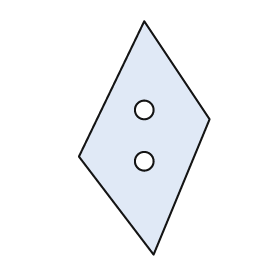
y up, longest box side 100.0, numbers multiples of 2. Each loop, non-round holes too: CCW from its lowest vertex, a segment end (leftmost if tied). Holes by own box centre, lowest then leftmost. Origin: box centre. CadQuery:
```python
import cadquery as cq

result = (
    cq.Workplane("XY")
    .moveTo(4.0, -50.0)
    .lineTo(28.0, 8.0)
    .lineTo(0.0, 50.0)
    .lineTo(-28.0, -8.0)
    .close()
    .moveTo(0.0, -10.0)
    .circle(4.0)
    .moveTo(0.0, 12.0)
    .circle(4.0)
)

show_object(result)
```